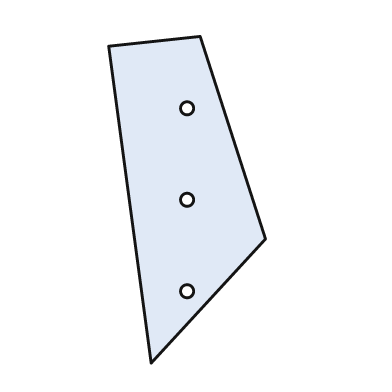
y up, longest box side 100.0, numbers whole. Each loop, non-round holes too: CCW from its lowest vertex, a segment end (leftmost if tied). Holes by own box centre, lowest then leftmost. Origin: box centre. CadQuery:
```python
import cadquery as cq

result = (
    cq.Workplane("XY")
    .moveTo(-11.0, -50.0)
    .lineTo(24.0, -12.0)
    .lineTo(4.0, 50.0)
    .lineTo(-24.0, 47.0)
    .close()
    .moveTo(0.0, -28.0)
    .circle(2.0)
    .moveTo(0.0, 0.0)
    .circle(2.0)
    .moveTo(0.0, 28.0)
    .circle(2.0)
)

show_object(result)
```